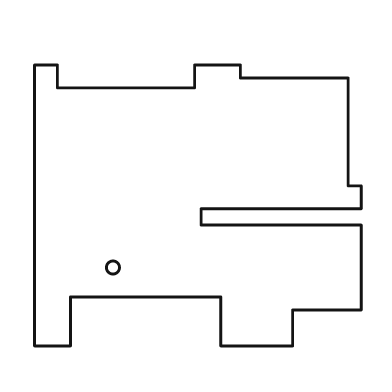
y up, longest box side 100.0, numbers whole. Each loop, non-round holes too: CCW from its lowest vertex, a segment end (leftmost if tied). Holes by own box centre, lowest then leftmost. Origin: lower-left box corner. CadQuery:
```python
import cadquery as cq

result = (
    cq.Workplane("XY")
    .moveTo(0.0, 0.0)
    .lineTo(11.0, 0.0)
    .lineTo(11.0, 15.0)
    .lineTo(57.0, 15.0)
    .lineTo(57.0, 0.0)
    .lineTo(79.0, 0.0)
    .lineTo(79.0, 11.0)
    .lineTo(100.0, 11.0)
    .lineTo(100.0, 37.0)
    .lineTo(51.0, 37.0)
    .lineTo(51.0, 42.0)
    .lineTo(100.0, 42.0)
    .lineTo(100.0, 49.0)
    .lineTo(96.0, 49.0)
    .lineTo(96.0, 82.0)
    .lineTo(63.0, 82.0)
    .lineTo(63.0, 86.0)
    .lineTo(49.0, 86.0)
    .lineTo(49.0, 79.0)
    .lineTo(7.0, 79.0)
    .lineTo(7.0, 86.0)
    .lineTo(0.0, 86.0)
    .close()
    .moveTo(24.0, 24.0)
    .circle(2.0)
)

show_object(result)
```